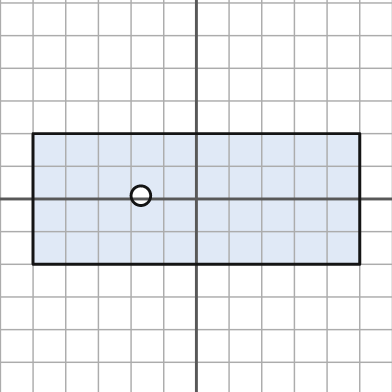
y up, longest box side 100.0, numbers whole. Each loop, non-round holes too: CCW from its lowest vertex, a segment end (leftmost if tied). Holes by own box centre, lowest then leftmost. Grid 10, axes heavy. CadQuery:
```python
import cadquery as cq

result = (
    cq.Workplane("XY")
    .moveTo(-50.0, -20.0)
    .lineTo(50.0, -20.0)
    .lineTo(50.0, 20.0)
    .lineTo(-50.0, 20.0)
    .close()
    .moveTo(-17.0, 1.0)
    .circle(3.0)
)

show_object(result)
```